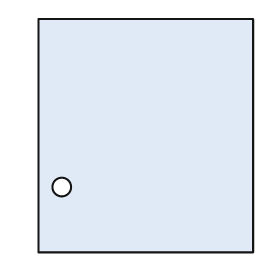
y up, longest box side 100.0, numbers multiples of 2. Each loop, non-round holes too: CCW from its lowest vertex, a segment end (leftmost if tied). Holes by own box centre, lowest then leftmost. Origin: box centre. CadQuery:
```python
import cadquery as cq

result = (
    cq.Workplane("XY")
    .moveTo(-46.0, -50.0)
    .lineTo(46.0, -50.0)
    .lineTo(46.0, 50.0)
    .lineTo(-46.0, 50.0)
    .close()
    .moveTo(-36.0, -22.0)
    .circle(4.0)
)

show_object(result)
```